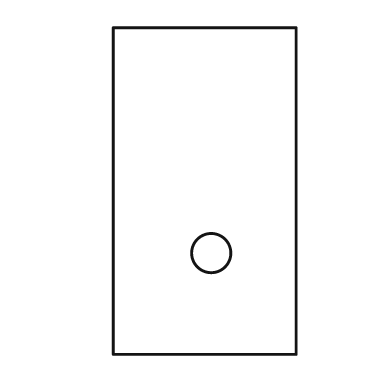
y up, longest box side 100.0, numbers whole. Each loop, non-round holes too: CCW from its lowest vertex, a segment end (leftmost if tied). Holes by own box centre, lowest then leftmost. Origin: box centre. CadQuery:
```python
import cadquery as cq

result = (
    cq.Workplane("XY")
    .moveTo(-28.0, -50.0)
    .lineTo(28.0, -50.0)
    .lineTo(28.0, 50.0)
    .lineTo(-28.0, 50.0)
    .close()
    .moveTo(2.0, -19.0)
    .circle(6.0)
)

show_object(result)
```